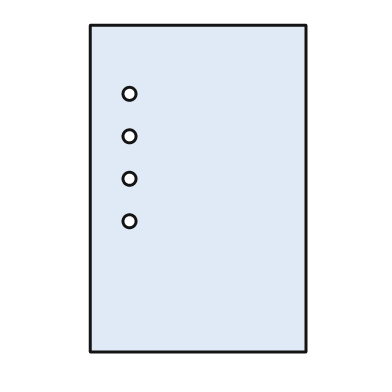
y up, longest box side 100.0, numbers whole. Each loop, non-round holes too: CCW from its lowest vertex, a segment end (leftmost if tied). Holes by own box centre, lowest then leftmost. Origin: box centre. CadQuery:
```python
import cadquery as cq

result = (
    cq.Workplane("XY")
    .moveTo(-33.0, -50.0)
    .lineTo(33.0, -50.0)
    .lineTo(33.0, 50.0)
    .lineTo(-33.0, 50.0)
    .close()
    .moveTo(-21.0, -10.0)
    .circle(2.0)
    .moveTo(-21.0, 3.0)
    .circle(2.0)
    .moveTo(-21.0, 16.0)
    .circle(2.0)
    .moveTo(-21.0, 29.0)
    .circle(2.0)
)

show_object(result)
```